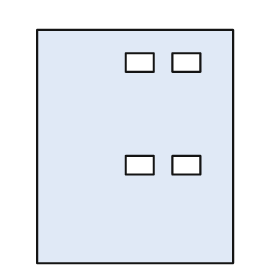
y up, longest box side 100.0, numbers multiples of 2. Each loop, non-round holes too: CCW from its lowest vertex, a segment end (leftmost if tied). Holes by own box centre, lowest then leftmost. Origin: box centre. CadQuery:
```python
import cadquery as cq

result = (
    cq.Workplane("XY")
    .moveTo(-42.0, -50.0)
    .lineTo(42.0, -50.0)
    .lineTo(42.0, 50.0)
    .lineTo(-42.0, 50.0)
    .close()
    .moveTo(-4.0, -12.0)
    .lineTo(8.0, -12.0)
    .lineTo(8.0, -4.0)
    .lineTo(-4.0, -4.0)
    .close()
    .moveTo(16.0, -12.0)
    .lineTo(28.0, -12.0)
    .lineTo(28.0, -4.0)
    .lineTo(16.0, -4.0)
    .close()
    .moveTo(-4.0, 32.0)
    .lineTo(8.0, 32.0)
    .lineTo(8.0, 40.0)
    .lineTo(-4.0, 40.0)
    .close()
    .moveTo(16.0, 32.0)
    .lineTo(28.0, 32.0)
    .lineTo(28.0, 40.0)
    .lineTo(16.0, 40.0)
    .close()
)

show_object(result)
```